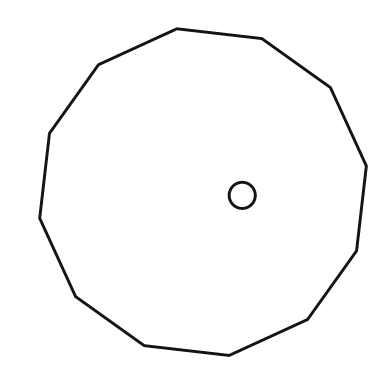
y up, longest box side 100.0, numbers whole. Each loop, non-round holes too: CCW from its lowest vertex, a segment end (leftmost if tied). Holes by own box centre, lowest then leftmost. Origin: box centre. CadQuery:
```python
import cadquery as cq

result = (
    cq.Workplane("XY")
    .moveTo(8.0, -50.0)
    .lineTo(32.0, -39.0)
    .lineTo(47.0, -18.0)
    .lineTo(50.0, 8.0)
    .lineTo(39.0, 32.0)
    .lineTo(18.0, 47.0)
    .lineTo(-8.0, 50.0)
    .lineTo(-32.0, 39.0)
    .lineTo(-47.0, 18.0)
    .lineTo(-50.0, -8.0)
    .lineTo(-39.0, -32.0)
    .lineTo(-18.0, -47.0)
    .close()
    .moveTo(12.0, -1.0)
    .circle(4.0)
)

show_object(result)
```